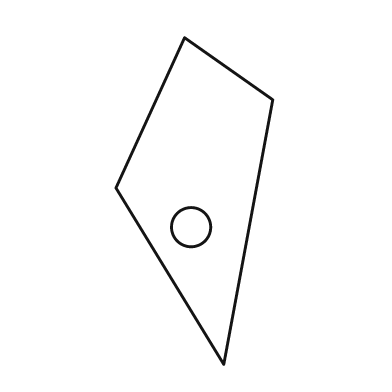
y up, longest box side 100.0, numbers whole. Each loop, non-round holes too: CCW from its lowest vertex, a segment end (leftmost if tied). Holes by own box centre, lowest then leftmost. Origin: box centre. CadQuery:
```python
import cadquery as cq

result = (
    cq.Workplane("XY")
    .moveTo(9.0, -50.0)
    .lineTo(24.0, 31.0)
    .lineTo(-3.0, 50.0)
    .lineTo(-24.0, 4.0)
    .close()
    .moveTo(-1.0, -8.0)
    .circle(6.0)
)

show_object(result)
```